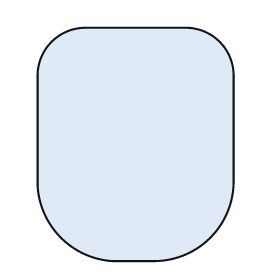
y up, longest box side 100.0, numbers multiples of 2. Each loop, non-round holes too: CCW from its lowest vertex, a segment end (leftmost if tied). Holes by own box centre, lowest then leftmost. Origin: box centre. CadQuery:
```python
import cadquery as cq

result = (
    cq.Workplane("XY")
    .moveTo(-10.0, -50.0)
    .lineTo(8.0, -50.0)
    .threePointArc((32.0, -40.0), (42.0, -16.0))
    .lineTo(42.0, 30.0)
    .threePointArc((36.0, 44.0), (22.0, 50.0))
    .lineTo(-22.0, 50.0)
    .threePointArc((-36.0, 44.0), (-42.0, 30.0))
    .lineTo(-42.0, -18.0)
    .threePointArc((-32.0, -40.0), (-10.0, -50.0))
    .close()
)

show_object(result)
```